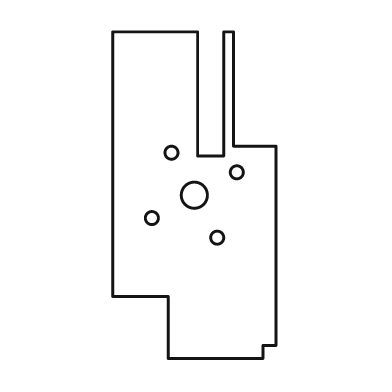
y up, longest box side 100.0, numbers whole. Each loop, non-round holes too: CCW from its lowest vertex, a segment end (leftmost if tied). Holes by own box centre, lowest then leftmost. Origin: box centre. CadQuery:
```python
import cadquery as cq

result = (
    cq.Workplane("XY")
    .moveTo(-8.0, -50.0)
    .lineTo(21.0, -50.0)
    .lineTo(21.0, -46.0)
    .lineTo(25.0, -46.0)
    .lineTo(25.0, 15.0)
    .lineTo(12.0, 15.0)
    .lineTo(12.0, 50.0)
    .lineTo(9.0, 50.0)
    .lineTo(9.0, 12.0)
    .lineTo(1.0, 12.0)
    .lineTo(1.0, 50.0)
    .lineTo(-25.0, 50.0)
    .lineTo(-25.0, -31.0)
    .lineTo(-8.0, -31.0)
    .close()
    .moveTo(7.0, -13.0)
    .circle(2.0)
    .moveTo(-13.0, -7.0)
    .circle(2.0)
    .moveTo(0.0, 0.0)
    .circle(4.0)
    .moveTo(13.0, 7.0)
    .circle(2.0)
    .moveTo(-7.0, 13.0)
    .circle(2.0)
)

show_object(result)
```